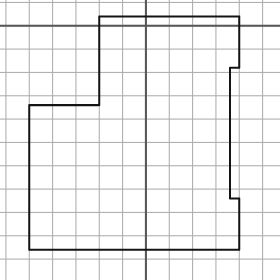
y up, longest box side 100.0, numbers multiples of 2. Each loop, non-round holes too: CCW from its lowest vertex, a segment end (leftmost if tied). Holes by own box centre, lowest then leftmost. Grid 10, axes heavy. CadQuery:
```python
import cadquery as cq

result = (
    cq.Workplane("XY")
    .moveTo(-50.0, -96.0)
    .lineTo(40.0, -96.0)
    .lineTo(40.0, -74.0)
    .lineTo(36.0, -74.0)
    .lineTo(36.0, -18.0)
    .lineTo(40.0, -18.0)
    .lineTo(40.0, 4.0)
    .lineTo(-20.0, 4.0)
    .lineTo(-20.0, -34.0)
    .lineTo(-50.0, -34.0)
    .close()
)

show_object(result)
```